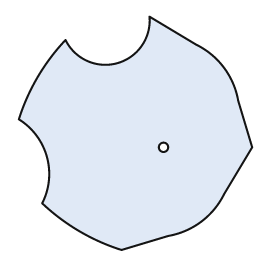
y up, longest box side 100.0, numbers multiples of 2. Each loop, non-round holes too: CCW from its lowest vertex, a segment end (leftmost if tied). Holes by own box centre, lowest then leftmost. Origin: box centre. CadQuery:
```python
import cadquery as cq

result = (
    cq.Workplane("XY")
    .moveTo(-6.0, -50.0)
    .lineTo(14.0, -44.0)
    .threePointArc((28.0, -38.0), (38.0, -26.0))
    .lineTo(50.0, -6.0)
    .lineTo(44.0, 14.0)
    .threePointArc((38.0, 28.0), (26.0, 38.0))
    .lineTo(6.0, 50.0)
    .threePointArc((-8.0, 30.0), (-30.0, 40.0))
    .threePointArc((-42.0, 24.0), (-50.0, 6.0))
    .threePointArc((-38.0, -10.0), (-40.0, -30.0))
    .threePointArc((-24.0, -42.0), (-6.0, -50.0))
    .close()
    .moveTo(12.0, -6.0)
    .circle(2.0)
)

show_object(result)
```